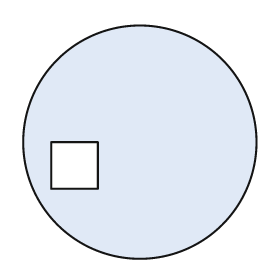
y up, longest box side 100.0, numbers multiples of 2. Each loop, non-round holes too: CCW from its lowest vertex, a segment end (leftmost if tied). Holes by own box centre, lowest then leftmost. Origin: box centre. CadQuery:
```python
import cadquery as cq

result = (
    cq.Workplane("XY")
    .moveTo(0.0, 0.0)
    .circle(50.0)
    .moveTo(-38.0, -20.0)
    .lineTo(-18.0, -20.0)
    .lineTo(-18.0, 0.0)
    .lineTo(-38.0, 0.0)
    .close()
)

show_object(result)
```